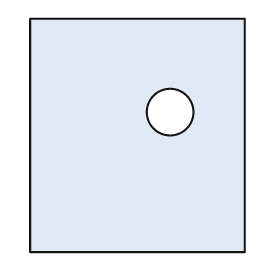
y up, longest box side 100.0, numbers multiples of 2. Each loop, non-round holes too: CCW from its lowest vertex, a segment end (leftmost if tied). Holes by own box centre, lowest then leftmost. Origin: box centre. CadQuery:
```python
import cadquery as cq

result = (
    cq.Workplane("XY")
    .moveTo(-46.0, -50.0)
    .lineTo(46.0, -50.0)
    .lineTo(46.0, 50.0)
    .lineTo(-46.0, 50.0)
    .close()
    .moveTo(14.0, 10.0)
    .circle(10.0)
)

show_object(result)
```